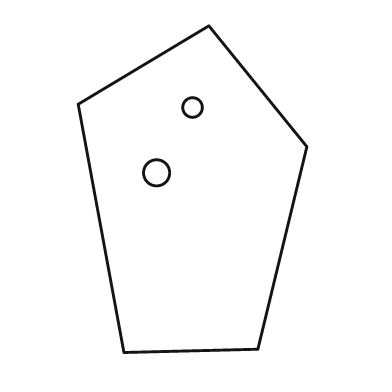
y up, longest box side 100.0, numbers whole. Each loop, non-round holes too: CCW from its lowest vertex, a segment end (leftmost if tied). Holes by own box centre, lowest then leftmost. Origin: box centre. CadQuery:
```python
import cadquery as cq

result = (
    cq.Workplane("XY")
    .moveTo(-21.0, -50.0)
    .lineTo(20.0, -49.0)
    .lineTo(35.0, 13.0)
    .lineTo(5.0, 50.0)
    .lineTo(-35.0, 26.0)
    .close()
    .moveTo(-11.0, 5.0)
    .circle(4.0)
    .moveTo(0.0, 25.0)
    .circle(3.0)
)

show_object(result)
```